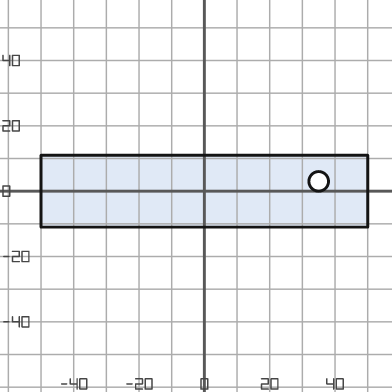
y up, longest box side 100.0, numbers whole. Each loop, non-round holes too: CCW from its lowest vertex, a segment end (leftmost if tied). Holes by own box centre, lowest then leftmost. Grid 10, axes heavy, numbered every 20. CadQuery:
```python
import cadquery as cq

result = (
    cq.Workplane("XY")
    .moveTo(-50.0, -11.0)
    .lineTo(50.0, -11.0)
    .lineTo(50.0, 11.0)
    .lineTo(-50.0, 11.0)
    .close()
    .moveTo(35.0, 3.0)
    .circle(3.0)
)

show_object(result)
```